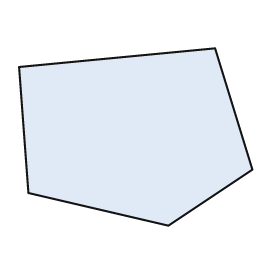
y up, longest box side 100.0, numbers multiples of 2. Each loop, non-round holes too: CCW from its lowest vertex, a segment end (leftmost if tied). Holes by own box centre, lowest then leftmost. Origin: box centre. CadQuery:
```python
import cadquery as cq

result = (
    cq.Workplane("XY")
    .moveTo(14.0, -38.0)
    .lineTo(50.0, -14.0)
    .lineTo(34.0, 38.0)
    .lineTo(-50.0, 30.0)
    .lineTo(-46.0, -24.0)
    .close()
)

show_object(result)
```